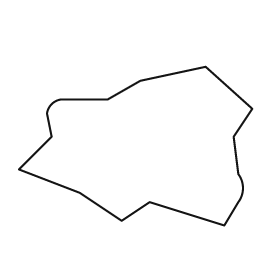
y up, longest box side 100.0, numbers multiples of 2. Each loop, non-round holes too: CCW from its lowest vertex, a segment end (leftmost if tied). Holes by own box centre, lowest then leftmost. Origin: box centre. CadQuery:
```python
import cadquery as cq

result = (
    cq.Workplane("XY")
    .moveTo(38.0, -34.0)
    .lineTo(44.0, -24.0)
    .threePointArc((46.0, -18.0), (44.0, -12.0))
    .lineTo(42.0, 4.0)
    .lineTo(50.0, 16.0)
    .lineTo(30.0, 34.0)
    .lineTo(2.0, 28.0)
    .lineTo(-12.0, 20.0)
    .lineTo(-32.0, 20.0)
    .threePointArc((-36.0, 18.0), (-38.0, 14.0))
    .lineTo(-36.0, 4.0)
    .lineTo(-50.0, -10.0)
    .lineTo(-24.0, -20.0)
    .lineTo(-6.0, -32.0)
    .lineTo(6.0, -24.0)
    .close()
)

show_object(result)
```